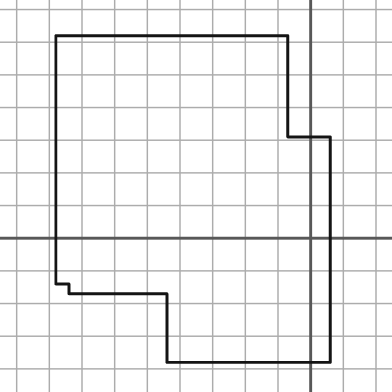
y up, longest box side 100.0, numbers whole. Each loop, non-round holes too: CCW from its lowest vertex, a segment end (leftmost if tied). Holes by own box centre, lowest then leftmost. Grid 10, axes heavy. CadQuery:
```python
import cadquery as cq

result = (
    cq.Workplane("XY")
    .moveTo(-44.0, -38.0)
    .lineTo(6.0, -38.0)
    .lineTo(6.0, 31.0)
    .lineTo(-7.0, 31.0)
    .lineTo(-7.0, 62.0)
    .lineTo(-78.0, 62.0)
    .lineTo(-78.0, -14.0)
    .lineTo(-74.0, -14.0)
    .lineTo(-74.0, -17.0)
    .lineTo(-44.0, -17.0)
    .close()
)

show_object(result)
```